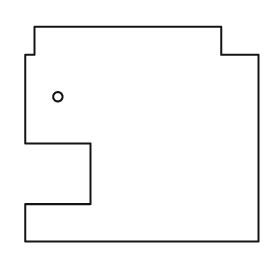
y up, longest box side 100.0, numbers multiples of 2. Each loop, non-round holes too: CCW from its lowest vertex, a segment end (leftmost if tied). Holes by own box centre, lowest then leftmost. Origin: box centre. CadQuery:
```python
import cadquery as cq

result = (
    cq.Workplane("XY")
    .moveTo(-50.0, -46.0)
    .lineTo(50.0, -46.0)
    .lineTo(50.0, 34.0)
    .lineTo(34.0, 34.0)
    .lineTo(34.0, 46.0)
    .lineTo(-46.0, 46.0)
    .lineTo(-46.0, 34.0)
    .lineTo(-50.0, 34.0)
    .lineTo(-50.0, -4.0)
    .lineTo(-22.0, -4.0)
    .lineTo(-22.0, -30.0)
    .lineTo(-50.0, -30.0)
    .close()
    .moveTo(-36.0, 16.0)
    .circle(2.0)
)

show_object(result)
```